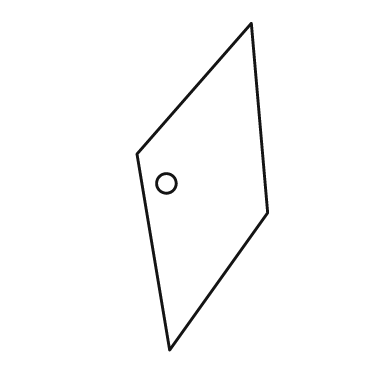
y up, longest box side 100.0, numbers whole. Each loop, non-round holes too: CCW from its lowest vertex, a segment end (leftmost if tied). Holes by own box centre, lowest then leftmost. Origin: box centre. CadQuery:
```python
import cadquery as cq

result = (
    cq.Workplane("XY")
    .moveTo(-10.0, -50.0)
    .lineTo(20.0, -8.0)
    .lineTo(15.0, 50.0)
    .lineTo(-20.0, 10.0)
    .close()
    .moveTo(-11.0, 1.0)
    .circle(3.0)
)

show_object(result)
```